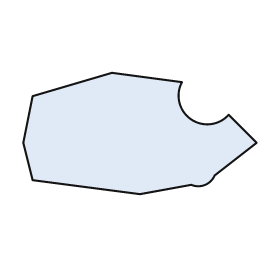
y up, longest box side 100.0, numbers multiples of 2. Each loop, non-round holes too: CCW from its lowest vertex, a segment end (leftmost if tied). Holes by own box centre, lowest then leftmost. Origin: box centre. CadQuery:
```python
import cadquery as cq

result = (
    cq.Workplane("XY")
    .moveTo(0.0, -26.0)
    .lineTo(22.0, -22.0)
    .threePointArc((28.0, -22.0), (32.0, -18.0))
    .lineTo(50.0, -4.0)
    .lineTo(38.0, 8.0)
    .threePointArc((22.0, 6.0), (18.0, 22.0))
    .lineTo(-12.0, 26.0)
    .lineTo(-46.0, 16.0)
    .lineTo(-50.0, -4.0)
    .lineTo(-46.0, -20.0)
    .close()
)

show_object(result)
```